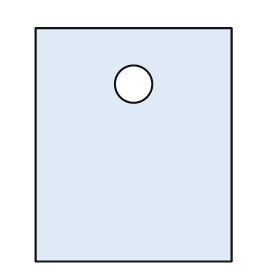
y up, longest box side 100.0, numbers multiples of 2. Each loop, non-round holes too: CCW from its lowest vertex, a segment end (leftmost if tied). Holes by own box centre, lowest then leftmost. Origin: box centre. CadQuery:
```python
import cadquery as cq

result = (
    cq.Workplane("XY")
    .moveTo(-42.0, -50.0)
    .lineTo(42.0, -50.0)
    .lineTo(42.0, 50.0)
    .lineTo(-42.0, 50.0)
    .close()
    .moveTo(0.0, 26.0)
    .circle(8.0)
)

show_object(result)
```